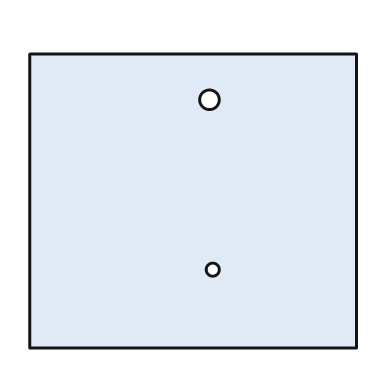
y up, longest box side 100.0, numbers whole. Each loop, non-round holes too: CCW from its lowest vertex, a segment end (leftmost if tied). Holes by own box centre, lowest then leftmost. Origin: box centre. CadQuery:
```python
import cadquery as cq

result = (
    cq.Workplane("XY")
    .moveTo(-50.0, -45.0)
    .lineTo(50.0, -45.0)
    .lineTo(50.0, 45.0)
    .lineTo(-50.0, 45.0)
    .close()
    .moveTo(6.0, -21.0)
    .circle(2.0)
    .moveTo(5.0, 31.0)
    .circle(3.0)
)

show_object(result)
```